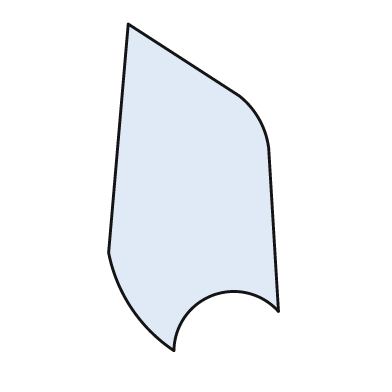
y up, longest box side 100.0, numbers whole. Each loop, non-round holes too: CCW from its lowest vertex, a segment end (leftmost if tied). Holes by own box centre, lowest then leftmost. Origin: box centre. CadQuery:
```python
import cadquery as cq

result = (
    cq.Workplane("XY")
    .moveTo(-6.0, -50.0)
    .threePointArc((6.0, -33.0), (26.0, -38.0))
    .lineTo(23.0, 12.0)
    .threePointArc((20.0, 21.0), (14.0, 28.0))
    .lineTo(-20.0, 50.0)
    .lineTo(-26.0, -20.0)
    .threePointArc((-19.0, -37.0), (-6.0, -50.0))
    .close()
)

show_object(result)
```